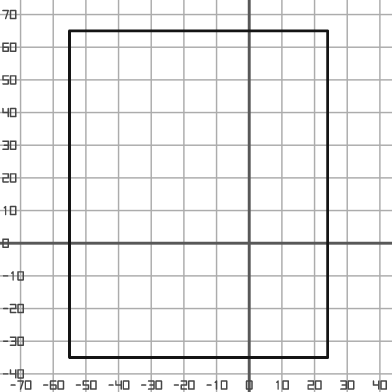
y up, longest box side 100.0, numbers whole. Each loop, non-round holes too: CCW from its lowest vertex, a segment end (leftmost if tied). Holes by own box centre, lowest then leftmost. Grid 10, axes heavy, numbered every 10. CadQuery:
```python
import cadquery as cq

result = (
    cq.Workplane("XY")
    .moveTo(-55.0, -35.0)
    .lineTo(24.0, -35.0)
    .lineTo(24.0, 65.0)
    .lineTo(-55.0, 65.0)
    .close()
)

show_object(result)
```